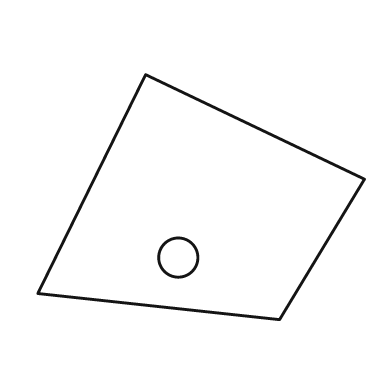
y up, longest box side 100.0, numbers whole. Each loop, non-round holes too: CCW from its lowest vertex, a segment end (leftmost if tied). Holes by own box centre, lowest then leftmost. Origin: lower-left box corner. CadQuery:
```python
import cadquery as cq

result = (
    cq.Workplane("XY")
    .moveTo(74.0, 0.0)
    .lineTo(100.0, 43.0)
    .lineTo(33.0, 75.0)
    .lineTo(0.0, 8.0)
    .close()
    .moveTo(43.0, 19.0)
    .circle(6.0)
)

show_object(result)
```